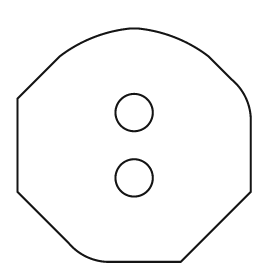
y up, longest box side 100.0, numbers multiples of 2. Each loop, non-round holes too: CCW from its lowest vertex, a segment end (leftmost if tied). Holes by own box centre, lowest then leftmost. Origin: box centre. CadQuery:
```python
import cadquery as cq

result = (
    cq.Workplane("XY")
    .moveTo(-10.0, -50.0)
    .lineTo(20.0, -50.0)
    .lineTo(50.0, -20.0)
    .lineTo(50.0, 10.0)
    .threePointArc((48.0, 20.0), (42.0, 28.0))
    .lineTo(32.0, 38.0)
    .threePointArc((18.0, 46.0), (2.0, 50.0))
    .lineTo(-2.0, 50.0)
    .threePointArc((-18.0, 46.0), (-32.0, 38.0))
    .lineTo(-50.0, 20.0)
    .lineTo(-50.0, -20.0)
    .lineTo(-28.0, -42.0)
    .threePointArc((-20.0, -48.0), (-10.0, -50.0))
    .close()
    .moveTo(0.0, -14.0)
    .circle(8.0)
    .moveTo(0.0, 14.0)
    .circle(8.0)
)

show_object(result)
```